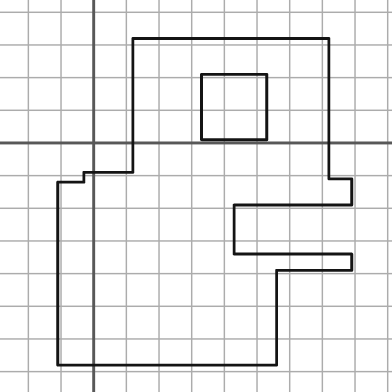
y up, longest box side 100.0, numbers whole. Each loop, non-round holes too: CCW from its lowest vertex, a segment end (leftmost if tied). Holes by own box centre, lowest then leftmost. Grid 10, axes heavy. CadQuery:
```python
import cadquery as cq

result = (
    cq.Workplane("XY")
    .moveTo(-11.0, -68.0)
    .lineTo(56.0, -68.0)
    .lineTo(56.0, -39.0)
    .lineTo(79.0, -39.0)
    .lineTo(79.0, -34.0)
    .lineTo(43.0, -34.0)
    .lineTo(43.0, -19.0)
    .lineTo(79.0, -19.0)
    .lineTo(79.0, -11.0)
    .lineTo(72.0, -11.0)
    .lineTo(72.0, 32.0)
    .lineTo(12.0, 32.0)
    .lineTo(12.0, -9.0)
    .lineTo(-3.0, -9.0)
    .lineTo(-3.0, -12.0)
    .lineTo(-11.0, -12.0)
    .close()
    .moveTo(33.0, 1.0)
    .lineTo(53.0, 1.0)
    .lineTo(53.0, 21.0)
    .lineTo(33.0, 21.0)
    .close()
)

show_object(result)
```